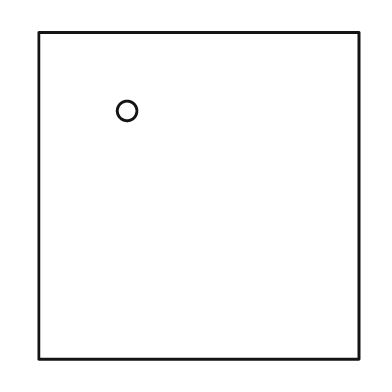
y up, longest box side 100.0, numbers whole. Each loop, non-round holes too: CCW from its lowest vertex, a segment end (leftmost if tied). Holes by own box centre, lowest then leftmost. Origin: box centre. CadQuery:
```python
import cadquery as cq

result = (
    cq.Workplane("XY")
    .moveTo(-49.0, -50.0)
    .lineTo(49.0, -50.0)
    .lineTo(49.0, 50.0)
    .lineTo(-49.0, 50.0)
    .close()
    .moveTo(-22.0, 26.0)
    .circle(3.0)
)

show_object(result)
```